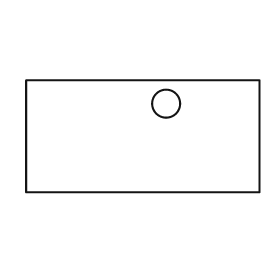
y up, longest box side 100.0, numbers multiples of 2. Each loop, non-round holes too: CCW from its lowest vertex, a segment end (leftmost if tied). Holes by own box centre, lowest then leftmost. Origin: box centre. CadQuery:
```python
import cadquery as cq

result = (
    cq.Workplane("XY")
    .moveTo(-50.0, -24.0)
    .lineTo(50.0, -24.0)
    .lineTo(50.0, 24.0)
    .lineTo(-50.0, 24.0)
    .close()
    .moveTo(10.0, 14.0)
    .circle(6.0)
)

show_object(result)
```